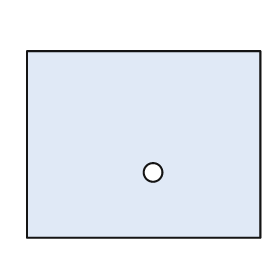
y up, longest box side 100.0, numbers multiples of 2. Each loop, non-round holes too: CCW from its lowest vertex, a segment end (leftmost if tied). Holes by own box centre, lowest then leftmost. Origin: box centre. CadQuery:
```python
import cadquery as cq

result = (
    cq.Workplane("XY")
    .moveTo(-50.0, -40.0)
    .lineTo(50.0, -40.0)
    .lineTo(50.0, 40.0)
    .lineTo(-50.0, 40.0)
    .close()
    .moveTo(4.0, -12.0)
    .circle(4.0)
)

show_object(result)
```